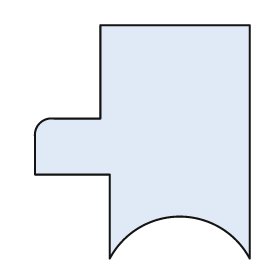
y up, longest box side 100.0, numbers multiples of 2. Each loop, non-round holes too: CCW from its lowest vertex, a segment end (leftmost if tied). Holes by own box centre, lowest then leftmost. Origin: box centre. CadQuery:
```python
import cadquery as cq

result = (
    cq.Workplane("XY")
    .moveTo(-14.0, -50.0)
    .threePointArc((16.0, -32.0), (46.0, -50.0))
    .lineTo(46.0, 50.0)
    .lineTo(-18.0, 50.0)
    .lineTo(-18.0, 10.0)
    .lineTo(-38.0, 10.0)
    .threePointArc((-44.0, 8.0), (-46.0, 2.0))
    .lineTo(-46.0, -14.0)
    .lineTo(-14.0, -14.0)
    .close()
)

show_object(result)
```